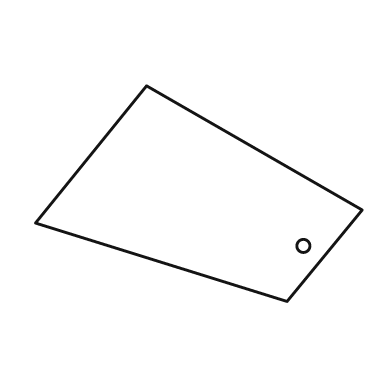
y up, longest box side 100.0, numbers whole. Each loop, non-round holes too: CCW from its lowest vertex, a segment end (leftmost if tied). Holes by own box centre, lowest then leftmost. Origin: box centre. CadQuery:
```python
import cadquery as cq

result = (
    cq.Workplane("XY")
    .moveTo(27.0, -33.0)
    .lineTo(50.0, -5.0)
    .lineTo(-16.0, 33.0)
    .lineTo(-50.0, -9.0)
    .close()
    .moveTo(32.0, -16.0)
    .circle(2.0)
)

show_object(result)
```